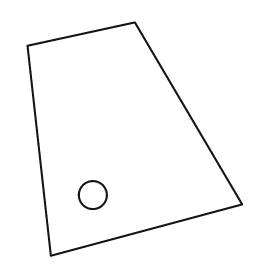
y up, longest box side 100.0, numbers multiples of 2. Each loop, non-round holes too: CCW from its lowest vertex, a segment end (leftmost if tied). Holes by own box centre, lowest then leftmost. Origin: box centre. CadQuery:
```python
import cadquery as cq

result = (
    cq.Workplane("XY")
    .moveTo(-36.0, -50.0)
    .lineTo(46.0, -28.0)
    .lineTo(0.0, 50.0)
    .lineTo(-46.0, 40.0)
    .close()
    .moveTo(-18.0, -24.0)
    .circle(6.0)
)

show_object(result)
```